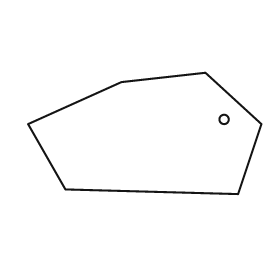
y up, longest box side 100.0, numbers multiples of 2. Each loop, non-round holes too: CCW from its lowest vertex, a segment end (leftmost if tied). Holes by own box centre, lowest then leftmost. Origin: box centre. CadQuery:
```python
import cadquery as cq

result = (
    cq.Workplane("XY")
    .moveTo(40.0, -26.0)
    .lineTo(50.0, 4.0)
    .lineTo(26.0, 26.0)
    .lineTo(-10.0, 22.0)
    .lineTo(-50.0, 4.0)
    .lineTo(-34.0, -24.0)
    .close()
    .moveTo(34.0, 6.0)
    .circle(2.0)
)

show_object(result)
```